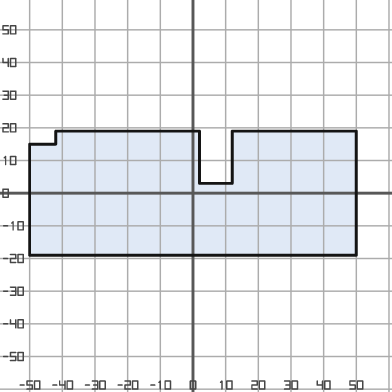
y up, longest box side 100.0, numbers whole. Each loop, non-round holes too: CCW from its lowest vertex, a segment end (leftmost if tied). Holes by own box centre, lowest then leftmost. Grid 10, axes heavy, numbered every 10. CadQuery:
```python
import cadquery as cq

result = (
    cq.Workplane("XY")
    .moveTo(-50.0, -19.0)
    .lineTo(50.0, -19.0)
    .lineTo(50.0, 19.0)
    .lineTo(12.0, 19.0)
    .lineTo(12.0, 3.0)
    .lineTo(2.0, 3.0)
    .lineTo(2.0, 19.0)
    .lineTo(-42.0, 19.0)
    .lineTo(-42.0, 15.0)
    .lineTo(-50.0, 15.0)
    .close()
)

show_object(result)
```